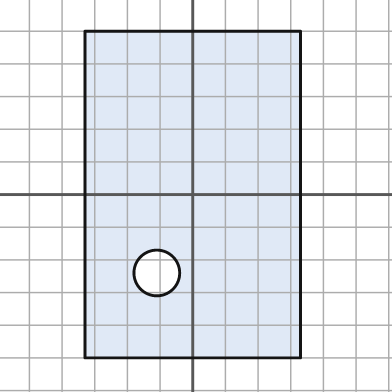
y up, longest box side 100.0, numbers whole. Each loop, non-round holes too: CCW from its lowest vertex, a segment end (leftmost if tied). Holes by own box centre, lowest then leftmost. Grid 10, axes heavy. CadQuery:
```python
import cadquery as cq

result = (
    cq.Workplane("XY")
    .moveTo(-33.0, -50.0)
    .lineTo(33.0, -50.0)
    .lineTo(33.0, 50.0)
    .lineTo(-33.0, 50.0)
    .close()
    .moveTo(-11.0, -24.0)
    .circle(7.0)
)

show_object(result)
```